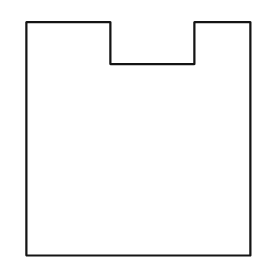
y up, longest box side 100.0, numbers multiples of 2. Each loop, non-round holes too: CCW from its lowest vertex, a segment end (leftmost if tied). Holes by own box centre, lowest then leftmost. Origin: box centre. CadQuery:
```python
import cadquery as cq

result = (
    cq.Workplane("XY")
    .moveTo(-48.0, -50.0)
    .lineTo(48.0, -50.0)
    .lineTo(48.0, 50.0)
    .lineTo(24.0, 50.0)
    .lineTo(24.0, 32.0)
    .lineTo(-12.0, 32.0)
    .lineTo(-12.0, 50.0)
    .lineTo(-48.0, 50.0)
    .close()
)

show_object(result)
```